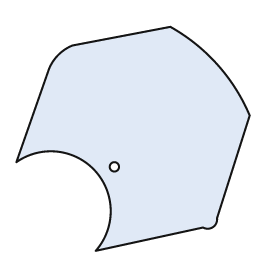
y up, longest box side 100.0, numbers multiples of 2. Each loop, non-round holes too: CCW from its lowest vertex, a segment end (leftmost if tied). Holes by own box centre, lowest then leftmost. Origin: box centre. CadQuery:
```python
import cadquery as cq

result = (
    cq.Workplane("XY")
    .moveTo(-16.0, -48.0)
    .lineTo(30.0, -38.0)
    .threePointArc((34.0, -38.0), (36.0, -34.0))
    .lineTo(50.0, 10.0)
    .threePointArc((36.0, 32.0), (16.0, 48.0))
    .lineTo(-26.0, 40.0)
    .threePointArc((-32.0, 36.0), (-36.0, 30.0))
    .lineTo(-50.0, -10.0)
    .threePointArc((-16.0, -14.0), (-16.0, -48.0))
    .close()
    .moveTo(-8.0, -12.0)
    .circle(2.0)
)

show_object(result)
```